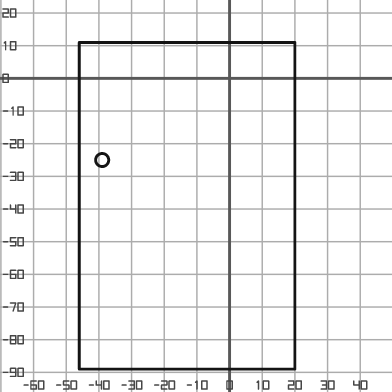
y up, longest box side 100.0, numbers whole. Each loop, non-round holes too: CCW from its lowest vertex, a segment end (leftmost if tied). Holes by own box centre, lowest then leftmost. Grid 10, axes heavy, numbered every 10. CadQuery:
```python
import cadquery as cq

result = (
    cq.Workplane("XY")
    .moveTo(-46.0, -89.0)
    .lineTo(20.0, -89.0)
    .lineTo(20.0, 11.0)
    .lineTo(-46.0, 11.0)
    .close()
    .moveTo(-39.0, -25.0)
    .circle(2.0)
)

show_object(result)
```